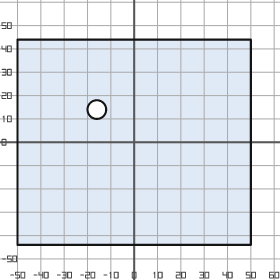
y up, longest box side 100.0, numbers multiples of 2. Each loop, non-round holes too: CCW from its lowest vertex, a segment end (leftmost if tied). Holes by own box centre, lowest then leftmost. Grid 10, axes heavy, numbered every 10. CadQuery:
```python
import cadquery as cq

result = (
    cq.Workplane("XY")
    .moveTo(-50.0, -44.0)
    .lineTo(50.0, -44.0)
    .lineTo(50.0, 44.0)
    .lineTo(-50.0, 44.0)
    .close()
    .moveTo(-16.0, 14.0)
    .circle(4.0)
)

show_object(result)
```